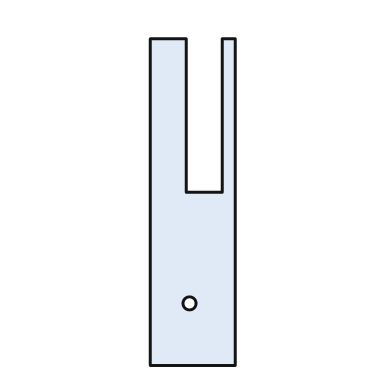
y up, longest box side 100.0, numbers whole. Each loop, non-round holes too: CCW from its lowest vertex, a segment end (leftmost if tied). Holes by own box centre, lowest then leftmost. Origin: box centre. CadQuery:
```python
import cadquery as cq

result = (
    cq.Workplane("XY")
    .moveTo(-13.0, -50.0)
    .lineTo(13.0, -50.0)
    .lineTo(13.0, 50.0)
    .lineTo(9.0, 50.0)
    .lineTo(9.0, 3.0)
    .lineTo(-2.0, 3.0)
    .lineTo(-2.0, 50.0)
    .lineTo(-13.0, 50.0)
    .close()
    .moveTo(-1.0, -31.0)
    .circle(2.0)
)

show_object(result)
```